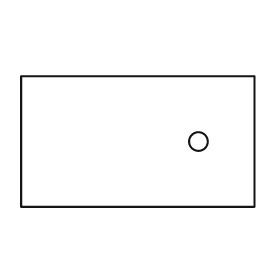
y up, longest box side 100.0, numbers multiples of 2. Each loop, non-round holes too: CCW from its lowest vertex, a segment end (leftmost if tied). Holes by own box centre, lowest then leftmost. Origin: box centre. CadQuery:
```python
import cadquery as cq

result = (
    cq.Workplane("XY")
    .moveTo(-50.0, -28.0)
    .lineTo(50.0, -28.0)
    .lineTo(50.0, 28.0)
    .lineTo(-50.0, 28.0)
    .close()
    .moveTo(26.0, 0.0)
    .circle(4.0)
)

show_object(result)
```